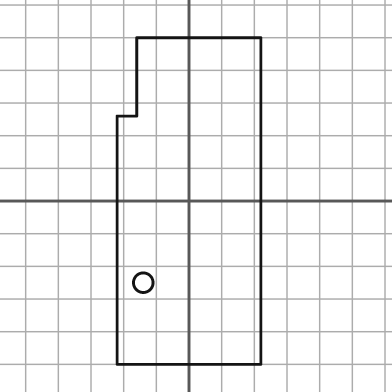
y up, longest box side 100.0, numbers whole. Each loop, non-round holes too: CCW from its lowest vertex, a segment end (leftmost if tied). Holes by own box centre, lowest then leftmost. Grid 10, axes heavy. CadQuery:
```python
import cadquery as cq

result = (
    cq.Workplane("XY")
    .moveTo(-22.0, -50.0)
    .lineTo(22.0, -50.0)
    .lineTo(22.0, 50.0)
    .lineTo(-16.0, 50.0)
    .lineTo(-16.0, 26.0)
    .lineTo(-22.0, 26.0)
    .close()
    .moveTo(-14.0, -25.0)
    .circle(3.0)
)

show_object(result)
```